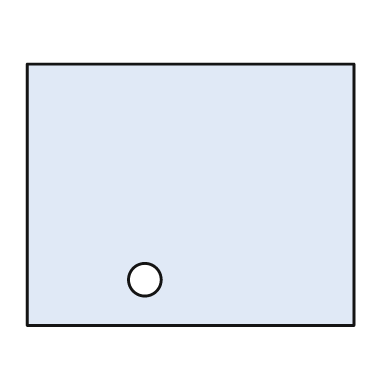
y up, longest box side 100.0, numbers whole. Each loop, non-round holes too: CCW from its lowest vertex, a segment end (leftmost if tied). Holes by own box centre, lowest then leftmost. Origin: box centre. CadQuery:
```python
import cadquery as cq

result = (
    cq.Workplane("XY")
    .moveTo(-50.0, -40.0)
    .lineTo(50.0, -40.0)
    .lineTo(50.0, 40.0)
    .lineTo(-50.0, 40.0)
    .close()
    .moveTo(-14.0, -26.0)
    .circle(5.0)
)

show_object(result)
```